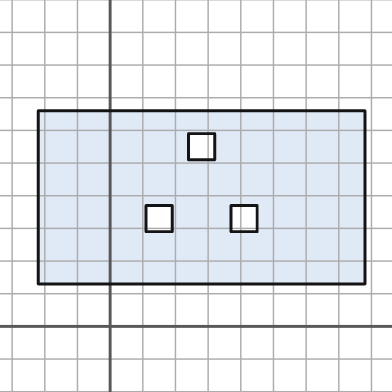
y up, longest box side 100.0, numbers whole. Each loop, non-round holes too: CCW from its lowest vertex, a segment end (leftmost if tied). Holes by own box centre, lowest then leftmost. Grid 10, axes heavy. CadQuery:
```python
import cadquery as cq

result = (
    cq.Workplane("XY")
    .moveTo(-22.0, 13.0)
    .lineTo(78.0, 13.0)
    .lineTo(78.0, 66.0)
    .lineTo(-22.0, 66.0)
    .close()
    .moveTo(11.0, 29.0)
    .lineTo(19.0, 29.0)
    .lineTo(19.0, 37.0)
    .lineTo(11.0, 37.0)
    .close()
    .moveTo(37.0, 29.0)
    .lineTo(45.0, 29.0)
    .lineTo(45.0, 37.0)
    .lineTo(37.0, 37.0)
    .close()
    .moveTo(24.0, 51.0)
    .lineTo(32.0, 51.0)
    .lineTo(32.0, 59.0)
    .lineTo(24.0, 59.0)
    .close()
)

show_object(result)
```